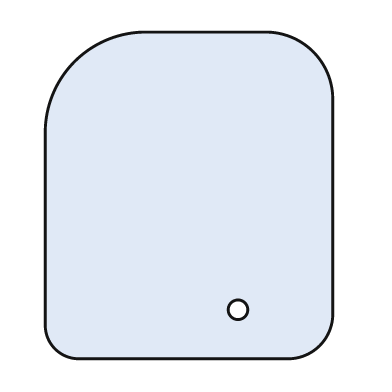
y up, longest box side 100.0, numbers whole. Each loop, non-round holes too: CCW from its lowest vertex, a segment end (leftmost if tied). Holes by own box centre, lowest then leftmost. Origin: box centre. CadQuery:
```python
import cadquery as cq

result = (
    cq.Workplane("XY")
    .moveTo(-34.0, -50.0)
    .lineTo(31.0, -50.0)
    .threePointArc((40.0, -46.0), (44.0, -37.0))
    .lineTo(44.0, 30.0)
    .threePointArc((38.0, 44.0), (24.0, 50.0))
    .lineTo(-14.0, 50.0)
    .threePointArc((-35.0, 41.0), (-44.0, 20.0))
    .lineTo(-44.0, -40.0)
    .threePointArc((-41.0, -47.0), (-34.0, -50.0))
    .close()
    .moveTo(15.0, -35.0)
    .circle(3.0)
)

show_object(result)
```